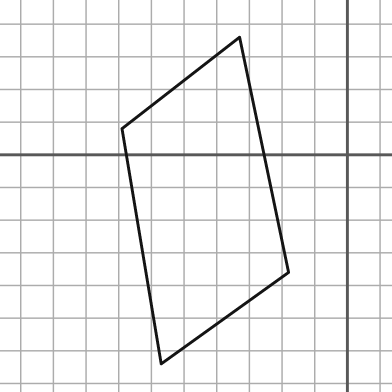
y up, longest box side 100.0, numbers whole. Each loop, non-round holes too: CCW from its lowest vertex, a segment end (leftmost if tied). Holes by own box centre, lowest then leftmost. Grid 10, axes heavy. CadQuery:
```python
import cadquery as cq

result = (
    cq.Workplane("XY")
    .moveTo(-57.0, -64.0)
    .lineTo(-18.0, -36.0)
    .lineTo(-33.0, 36.0)
    .lineTo(-69.0, 8.0)
    .close()
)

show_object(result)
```